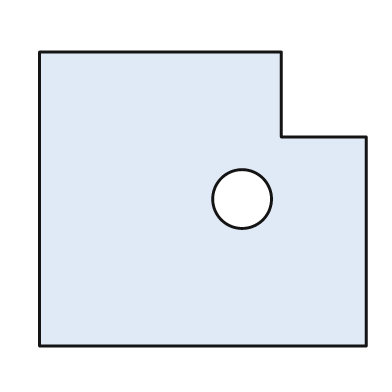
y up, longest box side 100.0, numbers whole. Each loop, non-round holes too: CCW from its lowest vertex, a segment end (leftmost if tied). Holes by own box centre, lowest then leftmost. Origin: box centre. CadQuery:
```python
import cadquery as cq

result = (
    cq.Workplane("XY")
    .moveTo(-50.0, -45.0)
    .lineTo(50.0, -45.0)
    .lineTo(50.0, 19.0)
    .lineTo(24.0, 19.0)
    .lineTo(24.0, 45.0)
    .lineTo(-50.0, 45.0)
    .close()
    .moveTo(12.0, 0.0)
    .circle(9.0)
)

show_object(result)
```